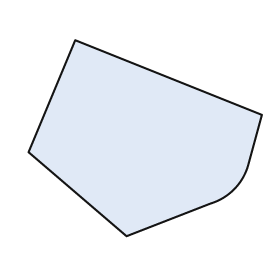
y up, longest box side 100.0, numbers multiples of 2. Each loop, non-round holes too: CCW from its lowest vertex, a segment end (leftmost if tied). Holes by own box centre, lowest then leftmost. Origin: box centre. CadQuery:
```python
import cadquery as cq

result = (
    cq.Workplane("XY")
    .moveTo(-8.0, -42.0)
    .lineTo(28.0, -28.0)
    .threePointArc((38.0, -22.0), (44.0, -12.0))
    .lineTo(50.0, 10.0)
    .lineTo(-30.0, 42.0)
    .lineTo(-50.0, -6.0)
    .close()
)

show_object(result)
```